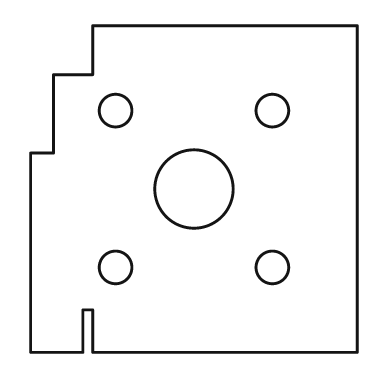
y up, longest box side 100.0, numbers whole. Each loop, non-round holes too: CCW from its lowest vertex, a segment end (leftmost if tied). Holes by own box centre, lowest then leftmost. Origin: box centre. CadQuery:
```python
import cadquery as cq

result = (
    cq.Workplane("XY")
    .moveTo(-50.0, -50.0)
    .lineTo(-34.0, -50.0)
    .lineTo(-34.0, -37.0)
    .lineTo(-31.0, -37.0)
    .lineTo(-31.0, -50.0)
    .lineTo(50.0, -50.0)
    .lineTo(50.0, 50.0)
    .lineTo(-31.0, 50.0)
    .lineTo(-31.0, 35.0)
    .lineTo(-43.0, 35.0)
    .lineTo(-43.0, 11.0)
    .lineTo(-50.0, 11.0)
    .close()
    .moveTo(-24.0, -24.0)
    .circle(5.0)
    .moveTo(24.0, -24.0)
    .circle(5.0)
    .moveTo(0.0, 0.0)
    .circle(12.0)
    .moveTo(-24.0, 24.0)
    .circle(5.0)
    .moveTo(24.0, 24.0)
    .circle(5.0)
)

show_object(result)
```